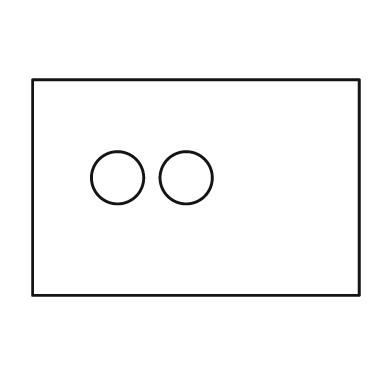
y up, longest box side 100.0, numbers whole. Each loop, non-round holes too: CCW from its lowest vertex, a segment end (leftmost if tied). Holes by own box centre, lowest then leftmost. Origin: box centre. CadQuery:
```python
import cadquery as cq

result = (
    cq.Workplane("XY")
    .moveTo(-50.0, -33.0)
    .lineTo(50.0, -33.0)
    .lineTo(50.0, 33.0)
    .lineTo(-50.0, 33.0)
    .close()
    .moveTo(-24.0, 3.0)
    .circle(8.0)
    .moveTo(-3.0, 3.0)
    .circle(8.0)
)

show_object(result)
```